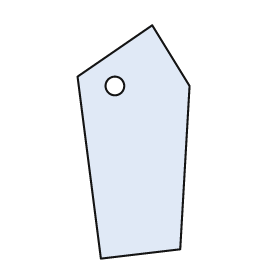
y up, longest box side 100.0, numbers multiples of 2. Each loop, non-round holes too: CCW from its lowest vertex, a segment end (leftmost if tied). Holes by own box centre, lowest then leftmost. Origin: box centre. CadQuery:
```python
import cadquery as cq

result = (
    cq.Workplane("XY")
    .moveTo(-14.0, -50.0)
    .lineTo(20.0, -46.0)
    .lineTo(24.0, 24.0)
    .lineTo(8.0, 50.0)
    .lineTo(-24.0, 28.0)
    .close()
    .moveTo(-8.0, 24.0)
    .circle(4.0)
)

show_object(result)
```